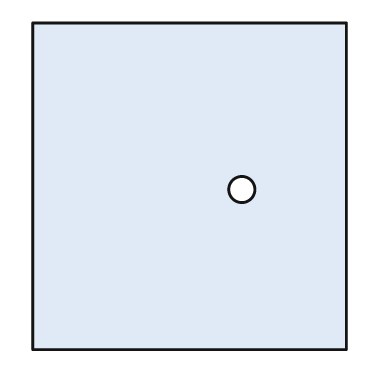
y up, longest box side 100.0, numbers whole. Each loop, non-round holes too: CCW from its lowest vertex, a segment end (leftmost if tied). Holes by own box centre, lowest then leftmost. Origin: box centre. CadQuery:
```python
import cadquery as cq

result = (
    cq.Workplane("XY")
    .moveTo(-48.0, -50.0)
    .lineTo(48.0, -50.0)
    .lineTo(48.0, 50.0)
    .lineTo(-48.0, 50.0)
    .close()
    .moveTo(16.0, -1.0)
    .circle(4.0)
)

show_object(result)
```